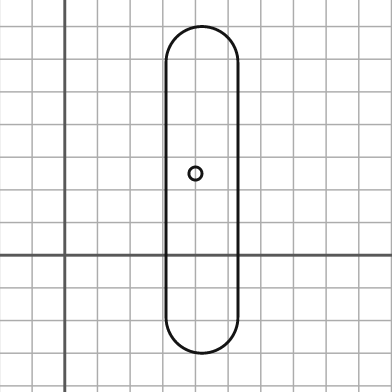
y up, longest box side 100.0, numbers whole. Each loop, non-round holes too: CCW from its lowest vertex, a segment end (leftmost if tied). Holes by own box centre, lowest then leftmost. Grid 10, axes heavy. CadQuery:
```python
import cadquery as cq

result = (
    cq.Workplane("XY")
    .moveTo(31.0, -19.0)
    .threePointArc((42.0, -30.0), (53.0, -19.0))
    .lineTo(53.0, 59.0)
    .threePointArc((42.0, 70.0), (31.0, 59.0))
    .close()
    .moveTo(40.0, 25.0)
    .circle(2.0)
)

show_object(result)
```